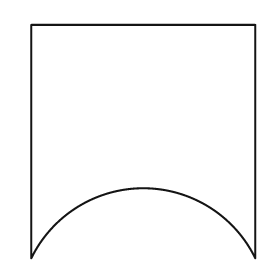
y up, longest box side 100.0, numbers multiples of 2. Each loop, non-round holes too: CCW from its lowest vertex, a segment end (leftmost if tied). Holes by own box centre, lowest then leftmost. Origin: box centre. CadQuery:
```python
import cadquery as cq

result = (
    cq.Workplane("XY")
    .moveTo(-48.0, -50.0)
    .threePointArc((0.0, -20.0), (48.0, -50.0))
    .lineTo(48.0, 50.0)
    .lineTo(-48.0, 50.0)
    .close()
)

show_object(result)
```